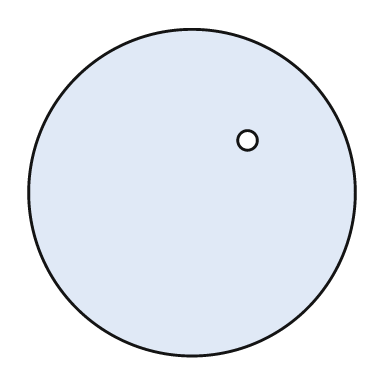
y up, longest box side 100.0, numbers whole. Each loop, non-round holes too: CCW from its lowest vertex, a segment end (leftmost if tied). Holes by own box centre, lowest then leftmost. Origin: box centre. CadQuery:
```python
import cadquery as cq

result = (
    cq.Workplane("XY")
    .moveTo(0.0, 0.0)
    .circle(50.0)
    .moveTo(17.0, 16.0)
    .circle(3.0)
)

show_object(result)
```